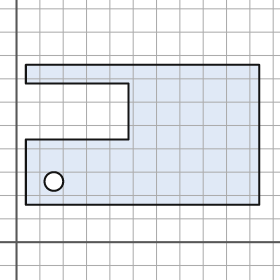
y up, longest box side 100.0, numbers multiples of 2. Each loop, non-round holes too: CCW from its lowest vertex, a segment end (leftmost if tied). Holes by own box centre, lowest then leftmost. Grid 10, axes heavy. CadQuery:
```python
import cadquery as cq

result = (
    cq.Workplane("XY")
    .moveTo(4.0, 16.0)
    .lineTo(104.0, 16.0)
    .lineTo(104.0, 76.0)
    .lineTo(4.0, 76.0)
    .lineTo(4.0, 68.0)
    .lineTo(48.0, 68.0)
    .lineTo(48.0, 44.0)
    .lineTo(4.0, 44.0)
    .close()
    .moveTo(16.0, 26.0)
    .circle(4.0)
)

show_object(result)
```